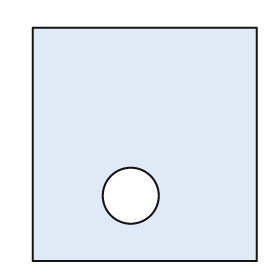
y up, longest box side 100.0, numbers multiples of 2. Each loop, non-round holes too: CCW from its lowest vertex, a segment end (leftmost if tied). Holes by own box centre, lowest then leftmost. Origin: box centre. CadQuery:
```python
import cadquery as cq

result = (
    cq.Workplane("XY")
    .moveTo(-48.0, -50.0)
    .lineTo(48.0, -50.0)
    .lineTo(48.0, 50.0)
    .lineTo(-48.0, 50.0)
    .close()
    .moveTo(-6.0, -22.0)
    .circle(12.0)
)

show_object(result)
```